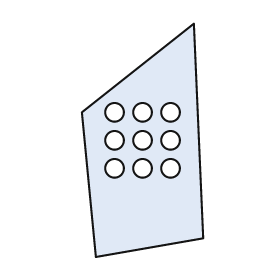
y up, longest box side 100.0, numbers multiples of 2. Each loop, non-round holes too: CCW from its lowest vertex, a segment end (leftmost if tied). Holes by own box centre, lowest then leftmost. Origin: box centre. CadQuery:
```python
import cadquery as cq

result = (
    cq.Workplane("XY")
    .moveTo(-20.0, -50.0)
    .lineTo(26.0, -42.0)
    .lineTo(22.0, 50.0)
    .lineTo(-26.0, 12.0)
    .close()
    .moveTo(-12.0, -12.0)
    .circle(4.0)
    .moveTo(0.0, -12.0)
    .circle(4.0)
    .moveTo(12.0, -12.0)
    .circle(4.0)
    .moveTo(-12.0, 0.0)
    .circle(4.0)
    .moveTo(0.0, 0.0)
    .circle(4.0)
    .moveTo(12.0, 0.0)
    .circle(4.0)
    .moveTo(-12.0, 12.0)
    .circle(4.0)
    .moveTo(0.0, 12.0)
    .circle(4.0)
    .moveTo(12.0, 12.0)
    .circle(4.0)
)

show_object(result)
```